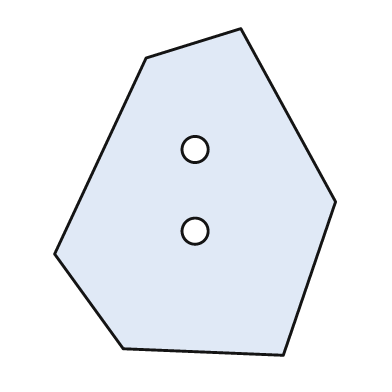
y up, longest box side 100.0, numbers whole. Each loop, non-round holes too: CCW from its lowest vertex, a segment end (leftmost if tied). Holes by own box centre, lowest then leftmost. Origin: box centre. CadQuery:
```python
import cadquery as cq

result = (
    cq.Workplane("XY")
    .moveTo(27.0, -50.0)
    .lineTo(43.0, -3.0)
    .lineTo(14.0, 50.0)
    .lineTo(-15.0, 41.0)
    .lineTo(-43.0, -19.0)
    .lineTo(-22.0, -48.0)
    .close()
    .moveTo(0.0, -12.0)
    .circle(4.0)
    .moveTo(0.0, 13.0)
    .circle(4.0)
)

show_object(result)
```